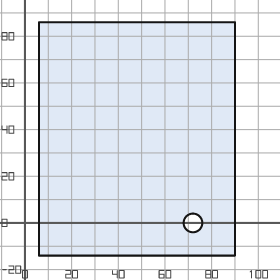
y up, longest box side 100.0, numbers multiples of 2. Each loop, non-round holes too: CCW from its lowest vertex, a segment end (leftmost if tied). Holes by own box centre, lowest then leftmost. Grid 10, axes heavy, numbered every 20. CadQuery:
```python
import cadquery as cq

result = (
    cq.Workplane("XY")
    .moveTo(6.0, -14.0)
    .lineTo(90.0, -14.0)
    .lineTo(90.0, 86.0)
    .lineTo(6.0, 86.0)
    .close()
    .moveTo(72.0, 0.0)
    .circle(4.0)
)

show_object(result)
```